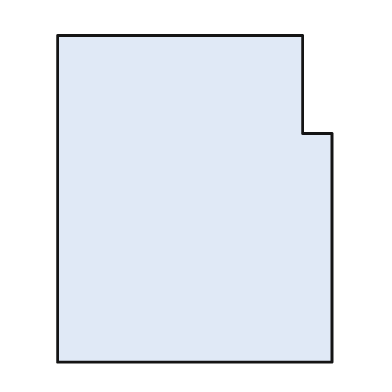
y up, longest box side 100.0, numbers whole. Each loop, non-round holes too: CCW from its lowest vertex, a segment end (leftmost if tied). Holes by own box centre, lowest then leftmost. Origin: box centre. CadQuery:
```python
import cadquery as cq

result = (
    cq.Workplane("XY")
    .moveTo(-42.0, -50.0)
    .lineTo(42.0, -50.0)
    .lineTo(42.0, 20.0)
    .lineTo(33.0, 20.0)
    .lineTo(33.0, 50.0)
    .lineTo(-42.0, 50.0)
    .close()
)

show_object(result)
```